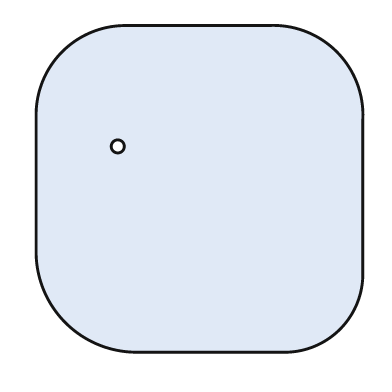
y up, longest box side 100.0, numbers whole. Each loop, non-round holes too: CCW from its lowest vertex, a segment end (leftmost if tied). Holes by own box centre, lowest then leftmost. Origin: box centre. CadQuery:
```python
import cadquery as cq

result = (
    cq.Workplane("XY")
    .moveTo(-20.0, -50.0)
    .lineTo(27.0, -50.0)
    .threePointArc((43.0, -43.0), (50.0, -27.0))
    .lineTo(50.0, 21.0)
    .threePointArc((42.0, 42.0), (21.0, 50.0))
    .lineTo(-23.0, 50.0)
    .threePointArc((-42.0, 42.0), (-50.0, 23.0))
    .lineTo(-50.0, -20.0)
    .threePointArc((-41.0, -41.0), (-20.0, -50.0))
    .close()
    .moveTo(-25.0, 13.0)
    .circle(2.0)
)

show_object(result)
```